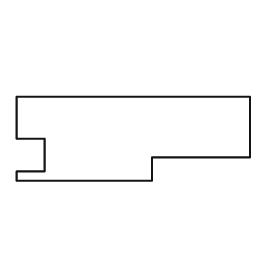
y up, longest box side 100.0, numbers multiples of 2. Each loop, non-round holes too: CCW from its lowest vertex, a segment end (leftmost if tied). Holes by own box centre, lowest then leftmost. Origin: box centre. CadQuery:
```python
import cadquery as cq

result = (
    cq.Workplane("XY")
    .moveTo(-50.0, -18.0)
    .lineTo(8.0, -18.0)
    .lineTo(8.0, -8.0)
    .lineTo(50.0, -8.0)
    .lineTo(50.0, 18.0)
    .lineTo(-50.0, 18.0)
    .lineTo(-50.0, 0.0)
    .lineTo(-38.0, 0.0)
    .lineTo(-38.0, -14.0)
    .lineTo(-50.0, -14.0)
    .close()
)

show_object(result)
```